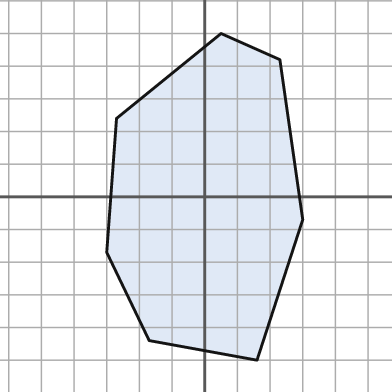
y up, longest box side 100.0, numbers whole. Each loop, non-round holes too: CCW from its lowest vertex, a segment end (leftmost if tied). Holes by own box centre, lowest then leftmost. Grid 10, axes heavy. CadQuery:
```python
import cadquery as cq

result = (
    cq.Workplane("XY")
    .moveTo(16.0, -50.0)
    .lineTo(30.0, -7.0)
    .lineTo(23.0, 42.0)
    .lineTo(5.0, 50.0)
    .lineTo(-27.0, 24.0)
    .lineTo(-30.0, -17.0)
    .lineTo(-17.0, -44.0)
    .close()
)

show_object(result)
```